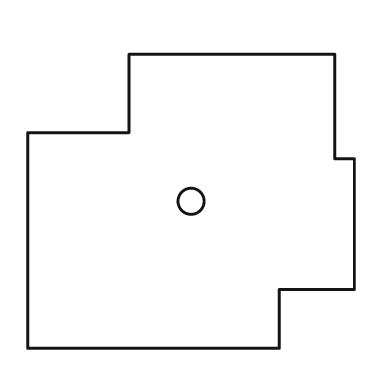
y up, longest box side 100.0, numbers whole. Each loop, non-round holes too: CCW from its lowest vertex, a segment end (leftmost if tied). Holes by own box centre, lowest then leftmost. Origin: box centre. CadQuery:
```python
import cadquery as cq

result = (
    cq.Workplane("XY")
    .moveTo(-50.0, -45.0)
    .lineTo(27.0, -45.0)
    .lineTo(27.0, -27.0)
    .lineTo(50.0, -27.0)
    .lineTo(50.0, 13.0)
    .lineTo(44.0, 13.0)
    .lineTo(44.0, 45.0)
    .lineTo(-19.0, 45.0)
    .lineTo(-19.0, 21.0)
    .lineTo(-50.0, 21.0)
    .close()
    .moveTo(0.0, 0.0)
    .circle(4.0)
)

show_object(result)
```